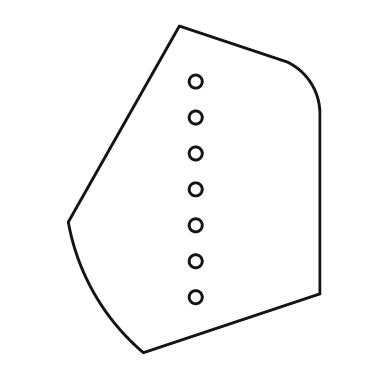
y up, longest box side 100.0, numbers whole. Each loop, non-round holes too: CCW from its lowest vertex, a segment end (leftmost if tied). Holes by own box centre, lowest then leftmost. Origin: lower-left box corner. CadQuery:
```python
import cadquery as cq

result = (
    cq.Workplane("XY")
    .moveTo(23.0, 0.0)
    .lineTo(77.0, 18.0)
    .lineTo(77.0, 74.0)
    .threePointArc((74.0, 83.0), (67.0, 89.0))
    .lineTo(34.0, 100.0)
    .lineTo(0.0, 40.0)
    .threePointArc((8.0, 18.0), (23.0, 0.0))
    .close()
    .moveTo(39.0, 17.0)
    .circle(2.0)
    .moveTo(39.0, 28.0)
    .circle(2.0)
    .moveTo(39.0, 39.0)
    .circle(2.0)
    .moveTo(39.0, 50.0)
    .circle(2.0)
    .moveTo(39.0, 61.0)
    .circle(2.0)
    .moveTo(39.0, 72.0)
    .circle(2.0)
    .moveTo(39.0, 83.0)
    .circle(2.0)
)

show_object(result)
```